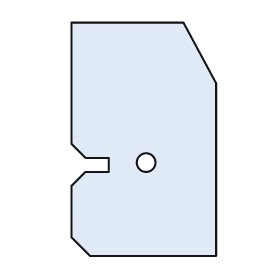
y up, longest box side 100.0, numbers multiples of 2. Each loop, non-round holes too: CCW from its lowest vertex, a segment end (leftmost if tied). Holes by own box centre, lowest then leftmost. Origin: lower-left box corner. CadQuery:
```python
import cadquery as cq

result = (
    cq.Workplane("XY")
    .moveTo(8.0, 0.0)
    .lineTo(62.0, 0.0)
    .lineTo(62.0, 74.0)
    .lineTo(48.0, 100.0)
    .lineTo(0.0, 100.0)
    .lineTo(0.0, 48.0)
    .lineTo(6.0, 42.0)
    .lineTo(16.0, 42.0)
    .lineTo(16.0, 36.0)
    .lineTo(6.0, 36.0)
    .lineTo(0.0, 30.0)
    .lineTo(0.0, 8.0)
    .close()
    .moveTo(32.0, 40.0)
    .circle(4.0)
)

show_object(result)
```